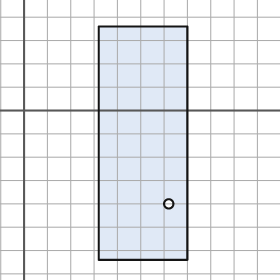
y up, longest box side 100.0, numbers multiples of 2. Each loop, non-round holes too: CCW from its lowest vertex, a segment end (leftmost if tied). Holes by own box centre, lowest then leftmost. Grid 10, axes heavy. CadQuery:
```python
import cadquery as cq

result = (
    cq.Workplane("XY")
    .moveTo(32.0, -64.0)
    .lineTo(70.0, -64.0)
    .lineTo(70.0, 36.0)
    .lineTo(32.0, 36.0)
    .close()
    .moveTo(62.0, -40.0)
    .circle(2.0)
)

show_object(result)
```